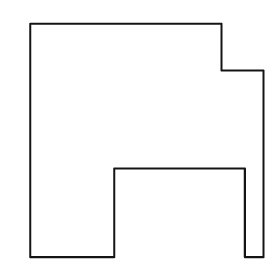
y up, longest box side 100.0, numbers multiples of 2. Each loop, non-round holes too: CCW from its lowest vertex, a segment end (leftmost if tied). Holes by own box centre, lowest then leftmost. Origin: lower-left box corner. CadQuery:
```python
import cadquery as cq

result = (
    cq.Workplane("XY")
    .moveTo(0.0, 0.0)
    .lineTo(36.0, 0.0)
    .lineTo(36.0, 38.0)
    .lineTo(92.0, 38.0)
    .lineTo(92.0, 0.0)
    .lineTo(100.0, 0.0)
    .lineTo(100.0, 80.0)
    .lineTo(82.0, 80.0)
    .lineTo(82.0, 100.0)
    .lineTo(0.0, 100.0)
    .close()
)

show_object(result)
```